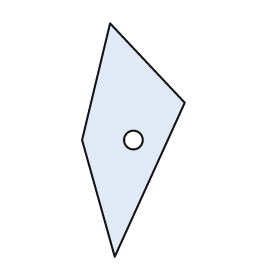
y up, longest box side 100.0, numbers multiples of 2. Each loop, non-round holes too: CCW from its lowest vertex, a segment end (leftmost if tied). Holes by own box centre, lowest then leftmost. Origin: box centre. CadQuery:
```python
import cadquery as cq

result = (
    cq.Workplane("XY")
    .moveTo(-8.0, -50.0)
    .lineTo(22.0, 16.0)
    .lineTo(-10.0, 50.0)
    .lineTo(-22.0, 0.0)
    .close()
    .moveTo(0.0, 0.0)
    .circle(4.0)
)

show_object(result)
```